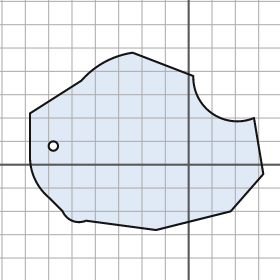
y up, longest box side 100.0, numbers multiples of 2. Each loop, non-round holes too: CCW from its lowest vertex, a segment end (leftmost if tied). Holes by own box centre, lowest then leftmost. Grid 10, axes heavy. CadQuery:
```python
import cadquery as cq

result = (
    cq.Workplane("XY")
    .moveTo(-14.0, -28.0)
    .lineTo(18.0, -20.0)
    .lineTo(32.0, -4.0)
    .lineTo(28.0, 20.0)
    .threePointArc((10.0, 22.0), (2.0, 38.0))
    .lineTo(-24.0, 48.0)
    .threePointArc((-36.0, 44.0), (-46.0, 36.0))
    .lineTo(-68.0, 22.0)
    .lineTo(-68.0, 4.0)
    .threePointArc((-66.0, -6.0), (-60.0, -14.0))
    .lineTo(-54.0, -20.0)
    .threePointArc((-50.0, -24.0), (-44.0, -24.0))
    .close()
    .moveTo(-58.0, 8.0)
    .circle(2.0)
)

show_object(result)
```